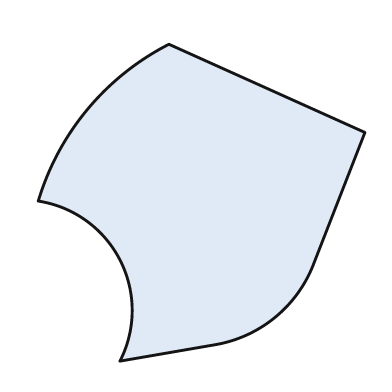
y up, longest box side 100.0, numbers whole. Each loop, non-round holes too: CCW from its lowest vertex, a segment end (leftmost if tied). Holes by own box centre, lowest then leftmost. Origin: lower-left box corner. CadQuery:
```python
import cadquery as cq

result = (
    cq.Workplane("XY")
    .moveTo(25.0, 0.0)
    .lineTo(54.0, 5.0)
    .threePointArc((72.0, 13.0), (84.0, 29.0))
    .lineTo(100.0, 70.0)
    .lineTo(40.0, 97.0)
    .threePointArc((15.0, 77.0), (0.0, 49.0))
    .threePointArc((25.0, 31.0), (25.0, 0.0))
    .close()
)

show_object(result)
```